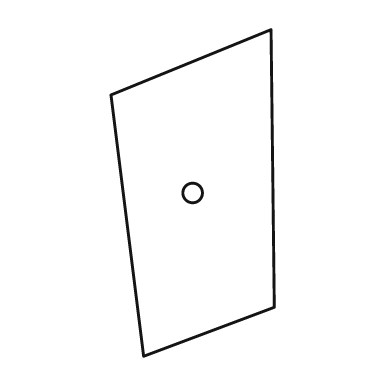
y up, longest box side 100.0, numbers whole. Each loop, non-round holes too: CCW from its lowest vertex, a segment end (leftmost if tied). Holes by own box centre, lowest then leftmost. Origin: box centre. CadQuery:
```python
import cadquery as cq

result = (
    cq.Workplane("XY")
    .moveTo(-15.0, -50.0)
    .lineTo(25.0, -35.0)
    .lineTo(24.0, 50.0)
    .lineTo(-25.0, 30.0)
    .close()
    .moveTo(0.0, 0.0)
    .circle(3.0)
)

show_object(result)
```